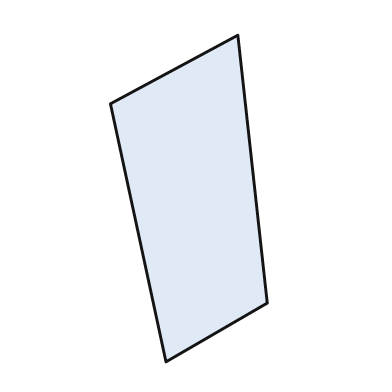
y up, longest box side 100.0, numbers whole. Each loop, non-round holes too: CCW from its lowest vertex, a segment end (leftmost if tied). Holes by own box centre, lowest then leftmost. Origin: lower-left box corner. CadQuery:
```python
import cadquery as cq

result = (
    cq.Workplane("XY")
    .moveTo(17.0, 0.0)
    .lineTo(48.0, 18.0)
    .lineTo(39.0, 100.0)
    .lineTo(0.0, 79.0)
    .close()
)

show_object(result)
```